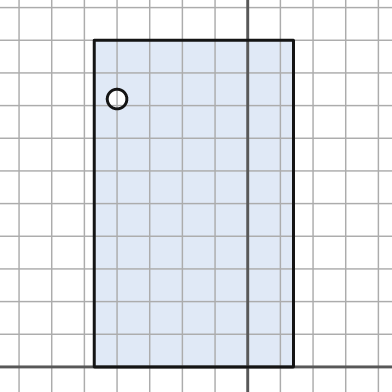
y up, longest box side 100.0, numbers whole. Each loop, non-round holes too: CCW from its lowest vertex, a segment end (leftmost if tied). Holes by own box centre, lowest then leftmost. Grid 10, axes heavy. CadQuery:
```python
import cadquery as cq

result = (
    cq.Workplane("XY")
    .moveTo(-47.0, 0.0)
    .lineTo(14.0, 0.0)
    .lineTo(14.0, 100.0)
    .lineTo(-47.0, 100.0)
    .close()
    .moveTo(-40.0, 82.0)
    .circle(3.0)
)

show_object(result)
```